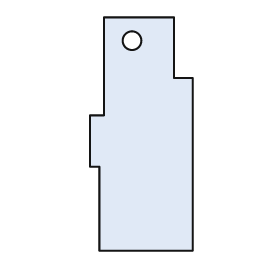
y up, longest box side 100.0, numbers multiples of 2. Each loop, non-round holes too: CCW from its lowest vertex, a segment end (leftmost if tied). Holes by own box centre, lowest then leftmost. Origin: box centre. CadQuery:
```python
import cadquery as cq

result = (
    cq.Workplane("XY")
    .moveTo(-18.0, -50.0)
    .lineTo(22.0, -50.0)
    .lineTo(22.0, 24.0)
    .lineTo(14.0, 24.0)
    .lineTo(14.0, 50.0)
    .lineTo(-16.0, 50.0)
    .lineTo(-16.0, 8.0)
    .lineTo(-22.0, 8.0)
    .lineTo(-22.0, -14.0)
    .lineTo(-18.0, -14.0)
    .close()
    .moveTo(-4.0, 40.0)
    .circle(4.0)
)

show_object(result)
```